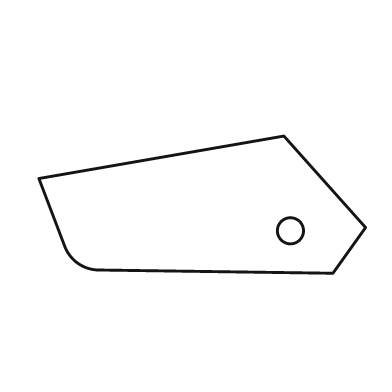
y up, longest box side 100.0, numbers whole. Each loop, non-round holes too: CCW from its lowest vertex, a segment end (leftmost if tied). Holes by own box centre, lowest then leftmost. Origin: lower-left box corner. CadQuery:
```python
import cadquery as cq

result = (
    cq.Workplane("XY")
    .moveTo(90.0, 0.0)
    .lineTo(100.0, 14.0)
    .lineTo(75.0, 42.0)
    .lineTo(0.0, 29.0)
    .lineTo(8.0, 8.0)
    .threePointArc((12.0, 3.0), (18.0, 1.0))
    .close()
    .moveTo(77.0, 13.0)
    .circle(4.0)
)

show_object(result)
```